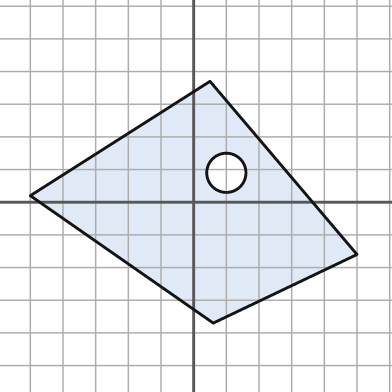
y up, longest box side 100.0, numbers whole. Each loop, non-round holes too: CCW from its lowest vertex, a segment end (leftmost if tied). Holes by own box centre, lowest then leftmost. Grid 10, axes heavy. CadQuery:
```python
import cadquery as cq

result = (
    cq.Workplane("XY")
    .moveTo(6.0, -37.0)
    .lineTo(50.0, -16.0)
    .lineTo(5.0, 37.0)
    .lineTo(-50.0, 2.0)
    .close()
    .moveTo(10.0, 9.0)
    .circle(6.0)
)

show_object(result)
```